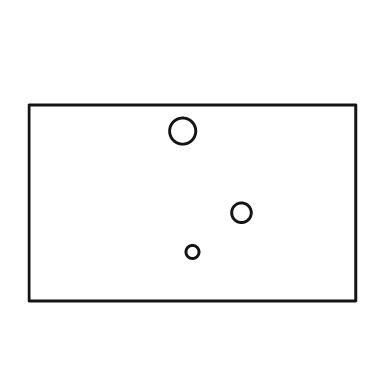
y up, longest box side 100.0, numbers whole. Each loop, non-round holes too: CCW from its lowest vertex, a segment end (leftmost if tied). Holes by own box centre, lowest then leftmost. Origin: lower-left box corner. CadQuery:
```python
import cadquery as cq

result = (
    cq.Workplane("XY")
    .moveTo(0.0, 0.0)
    .lineTo(100.0, 0.0)
    .lineTo(100.0, 60.0)
    .lineTo(0.0, 60.0)
    .close()
    .moveTo(50.0, 15.0)
    .circle(2.0)
    .moveTo(65.0, 27.0)
    .circle(3.0)
    .moveTo(47.0, 52.0)
    .circle(4.0)
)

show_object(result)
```